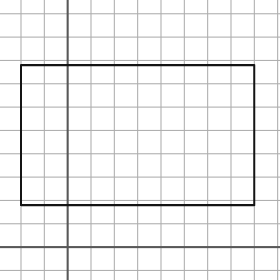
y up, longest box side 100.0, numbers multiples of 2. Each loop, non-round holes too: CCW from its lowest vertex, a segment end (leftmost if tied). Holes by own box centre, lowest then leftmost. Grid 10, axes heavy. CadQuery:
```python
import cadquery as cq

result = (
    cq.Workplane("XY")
    .moveTo(-20.0, 18.0)
    .lineTo(80.0, 18.0)
    .lineTo(80.0, 78.0)
    .lineTo(-20.0, 78.0)
    .close()
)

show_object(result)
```